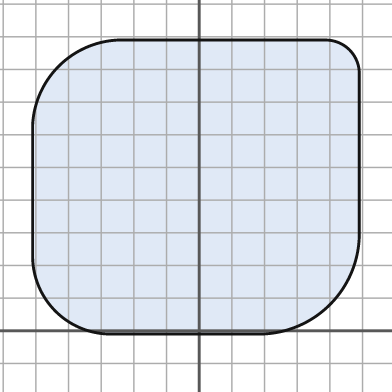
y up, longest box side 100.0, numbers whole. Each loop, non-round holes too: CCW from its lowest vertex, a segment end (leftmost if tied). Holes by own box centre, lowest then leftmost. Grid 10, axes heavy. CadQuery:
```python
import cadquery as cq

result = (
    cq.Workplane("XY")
    .moveTo(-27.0, -1.0)
    .lineTo(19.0, -1.0)
    .threePointArc((40.0, 8.0), (49.0, 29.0))
    .lineTo(49.0, 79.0)
    .threePointArc((46.0, 86.0), (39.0, 89.0))
    .lineTo(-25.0, 89.0)
    .threePointArc((-43.0, 81.0), (-51.0, 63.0))
    .lineTo(-51.0, 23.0)
    .threePointArc((-44.0, 6.0), (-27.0, -1.0))
    .close()
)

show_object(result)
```